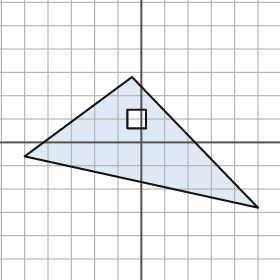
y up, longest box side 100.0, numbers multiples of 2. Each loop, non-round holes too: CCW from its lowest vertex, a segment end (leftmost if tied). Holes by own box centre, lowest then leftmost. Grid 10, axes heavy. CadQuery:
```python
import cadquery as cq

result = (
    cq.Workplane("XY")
    .moveTo(50.0, -28.0)
    .lineTo(-4.0, 28.0)
    .lineTo(-50.0, -6.0)
    .close()
    .moveTo(-6.0, 6.0)
    .lineTo(2.0, 6.0)
    .lineTo(2.0, 14.0)
    .lineTo(-6.0, 14.0)
    .close()
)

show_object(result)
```